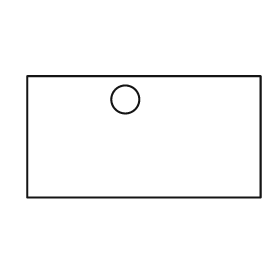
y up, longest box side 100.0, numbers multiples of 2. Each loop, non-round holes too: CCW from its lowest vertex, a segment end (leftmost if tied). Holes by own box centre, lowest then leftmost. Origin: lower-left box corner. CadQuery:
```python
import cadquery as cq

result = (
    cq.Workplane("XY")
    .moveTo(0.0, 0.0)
    .lineTo(100.0, 0.0)
    .lineTo(100.0, 52.0)
    .lineTo(0.0, 52.0)
    .close()
    .moveTo(42.0, 42.0)
    .circle(6.0)
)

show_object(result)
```